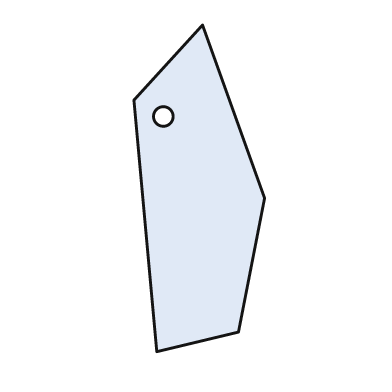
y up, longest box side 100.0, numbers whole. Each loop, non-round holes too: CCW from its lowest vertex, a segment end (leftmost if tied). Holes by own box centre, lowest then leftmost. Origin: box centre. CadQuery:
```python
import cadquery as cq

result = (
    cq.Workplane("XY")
    .moveTo(-13.0, -50.0)
    .lineTo(12.0, -44.0)
    .lineTo(20.0, -3.0)
    .lineTo(1.0, 50.0)
    .lineTo(-20.0, 27.0)
    .close()
    .moveTo(-11.0, 22.0)
    .circle(3.0)
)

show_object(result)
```